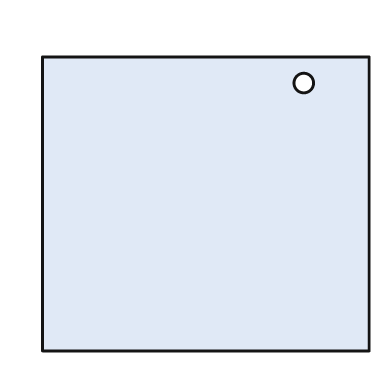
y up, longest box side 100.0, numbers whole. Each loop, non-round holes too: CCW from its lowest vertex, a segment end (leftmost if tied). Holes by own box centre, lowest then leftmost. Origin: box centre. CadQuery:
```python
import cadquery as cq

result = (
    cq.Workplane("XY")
    .moveTo(-50.0, -45.0)
    .lineTo(50.0, -45.0)
    .lineTo(50.0, 45.0)
    .lineTo(-50.0, 45.0)
    .close()
    .moveTo(30.0, 37.0)
    .circle(3.0)
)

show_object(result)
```